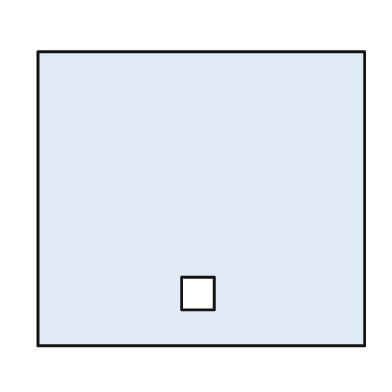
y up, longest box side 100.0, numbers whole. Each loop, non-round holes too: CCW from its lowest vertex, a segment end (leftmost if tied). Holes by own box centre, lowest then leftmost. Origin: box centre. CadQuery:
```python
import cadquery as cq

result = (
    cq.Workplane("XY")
    .moveTo(-50.0, -45.0)
    .lineTo(50.0, -45.0)
    .lineTo(50.0, 45.0)
    .lineTo(-50.0, 45.0)
    .close()
    .moveTo(-6.0, -34.0)
    .lineTo(4.0, -34.0)
    .lineTo(4.0, -24.0)
    .lineTo(-6.0, -24.0)
    .close()
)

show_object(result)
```